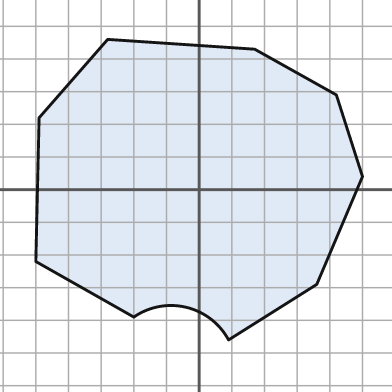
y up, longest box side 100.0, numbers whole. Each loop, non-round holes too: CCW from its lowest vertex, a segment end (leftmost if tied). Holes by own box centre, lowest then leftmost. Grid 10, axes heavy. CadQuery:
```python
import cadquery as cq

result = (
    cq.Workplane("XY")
    .moveTo(9.0, -46.0)
    .lineTo(36.0, -29.0)
    .lineTo(50.0, 4.0)
    .lineTo(42.0, 29.0)
    .lineTo(17.0, 43.0)
    .lineTo(-28.0, 46.0)
    .lineTo(-49.0, 22.0)
    .lineTo(-50.0, -22.0)
    .lineTo(-20.0, -39.0)
    .threePointArc((-4.0, -36.0), (9.0, -46.0))
    .close()
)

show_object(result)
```